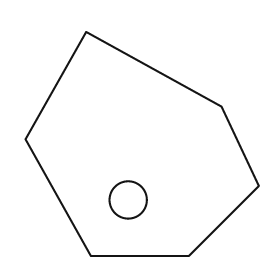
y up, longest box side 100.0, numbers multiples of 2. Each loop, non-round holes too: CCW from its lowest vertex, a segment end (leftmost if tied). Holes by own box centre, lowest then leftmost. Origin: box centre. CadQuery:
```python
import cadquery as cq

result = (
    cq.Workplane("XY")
    .moveTo(-22.0, -48.0)
    .lineTo(20.0, -48.0)
    .lineTo(50.0, -18.0)
    .lineTo(34.0, 16.0)
    .lineTo(-24.0, 48.0)
    .lineTo(-50.0, 2.0)
    .close()
    .moveTo(-6.0, -24.0)
    .circle(8.0)
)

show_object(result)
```